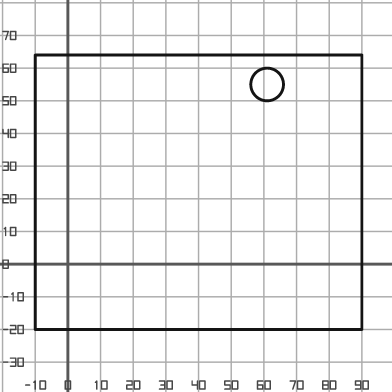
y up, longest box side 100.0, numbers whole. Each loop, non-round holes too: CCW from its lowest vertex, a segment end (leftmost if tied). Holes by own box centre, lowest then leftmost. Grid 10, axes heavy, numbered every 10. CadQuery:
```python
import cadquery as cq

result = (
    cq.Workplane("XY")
    .moveTo(-10.0, -20.0)
    .lineTo(90.0, -20.0)
    .lineTo(90.0, 64.0)
    .lineTo(-10.0, 64.0)
    .close()
    .moveTo(61.0, 55.0)
    .circle(5.0)
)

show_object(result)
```